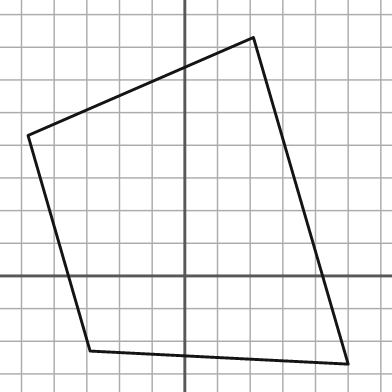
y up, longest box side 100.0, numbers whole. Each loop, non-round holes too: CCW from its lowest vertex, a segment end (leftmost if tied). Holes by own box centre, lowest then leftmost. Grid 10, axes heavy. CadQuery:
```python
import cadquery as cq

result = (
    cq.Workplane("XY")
    .moveTo(50.0, -27.0)
    .lineTo(21.0, 73.0)
    .lineTo(-48.0, 43.0)
    .lineTo(-29.0, -23.0)
    .close()
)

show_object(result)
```